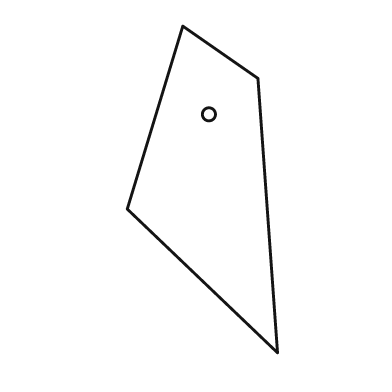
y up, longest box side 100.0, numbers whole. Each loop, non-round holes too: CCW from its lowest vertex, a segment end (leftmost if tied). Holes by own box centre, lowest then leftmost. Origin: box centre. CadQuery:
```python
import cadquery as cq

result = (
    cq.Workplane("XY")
    .moveTo(23.0, -50.0)
    .lineTo(17.0, 34.0)
    .lineTo(-6.0, 50.0)
    .lineTo(-23.0, -6.0)
    .close()
    .moveTo(2.0, 23.0)
    .circle(2.0)
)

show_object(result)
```